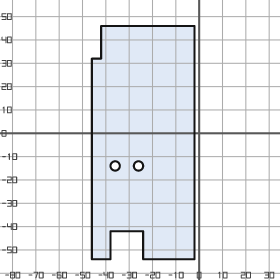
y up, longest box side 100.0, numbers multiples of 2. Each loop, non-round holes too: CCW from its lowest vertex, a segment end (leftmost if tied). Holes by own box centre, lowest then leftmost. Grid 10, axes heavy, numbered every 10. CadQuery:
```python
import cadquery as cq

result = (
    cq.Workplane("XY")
    .moveTo(-46.0, -54.0)
    .lineTo(-38.0, -54.0)
    .lineTo(-38.0, -42.0)
    .lineTo(-24.0, -42.0)
    .lineTo(-24.0, -54.0)
    .lineTo(-2.0, -54.0)
    .lineTo(-2.0, 46.0)
    .lineTo(-42.0, 46.0)
    .lineTo(-42.0, 32.0)
    .lineTo(-46.0, 32.0)
    .close()
    .moveTo(-36.0, -14.0)
    .circle(2.0)
    .moveTo(-26.0, -14.0)
    .circle(2.0)
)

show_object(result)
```